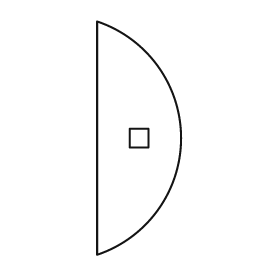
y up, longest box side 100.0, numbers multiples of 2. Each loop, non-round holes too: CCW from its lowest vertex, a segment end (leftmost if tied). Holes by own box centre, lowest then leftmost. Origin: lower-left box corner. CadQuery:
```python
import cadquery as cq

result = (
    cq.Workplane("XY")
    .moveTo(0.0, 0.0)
    .threePointArc((36.0, 50.0), (0.0, 100.0))
    .close()
    .moveTo(14.0, 46.0)
    .lineTo(22.0, 46.0)
    .lineTo(22.0, 54.0)
    .lineTo(14.0, 54.0)
    .close()
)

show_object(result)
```